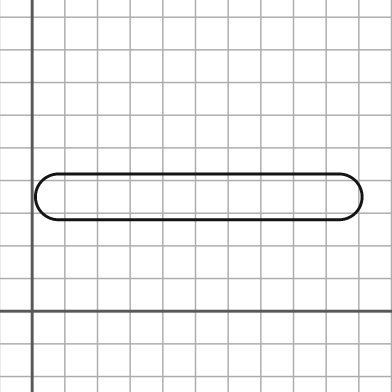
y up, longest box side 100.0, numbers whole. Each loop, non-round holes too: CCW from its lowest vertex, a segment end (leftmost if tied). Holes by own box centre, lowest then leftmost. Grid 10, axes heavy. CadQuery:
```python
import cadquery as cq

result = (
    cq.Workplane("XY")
    .moveTo(8.0, 28.0)
    .lineTo(94.0, 28.0)
    .threePointArc((101.0, 35.0), (94.0, 42.0))
    .lineTo(8.0, 42.0)
    .threePointArc((1.0, 35.0), (8.0, 28.0))
    .close()
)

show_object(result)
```